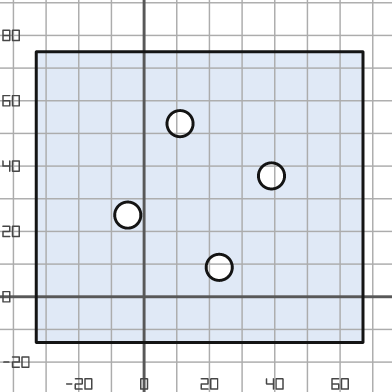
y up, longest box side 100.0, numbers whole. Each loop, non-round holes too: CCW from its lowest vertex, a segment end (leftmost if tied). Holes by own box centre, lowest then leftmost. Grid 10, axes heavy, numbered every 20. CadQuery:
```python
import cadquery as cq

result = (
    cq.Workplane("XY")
    .moveTo(-33.0, -14.0)
    .lineTo(67.0, -14.0)
    .lineTo(67.0, 75.0)
    .lineTo(-33.0, 75.0)
    .close()
    .moveTo(23.0, 9.0)
    .circle(4.0)
    .moveTo(-5.0, 25.0)
    .circle(4.0)
    .moveTo(39.0, 37.0)
    .circle(4.0)
    .moveTo(11.0, 53.0)
    .circle(4.0)
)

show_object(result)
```